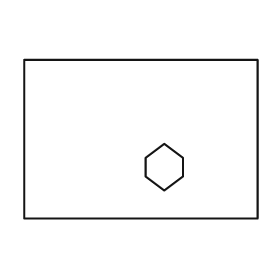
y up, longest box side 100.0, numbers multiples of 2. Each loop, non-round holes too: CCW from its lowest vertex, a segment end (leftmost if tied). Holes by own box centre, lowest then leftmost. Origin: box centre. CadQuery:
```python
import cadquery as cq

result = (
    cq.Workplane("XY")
    .moveTo(-50.0, -34.0)
    .lineTo(50.0, -34.0)
    .lineTo(50.0, 34.0)
    .lineTo(-50.0, 34.0)
    .close()
    .moveTo(10.0, -22.0)
    .lineTo(18.0, -16.0)
    .lineTo(18.0, -8.0)
    .lineTo(10.0, -2.0)
    .lineTo(2.0, -8.0)
    .lineTo(2.0, -16.0)
    .close()
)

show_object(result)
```